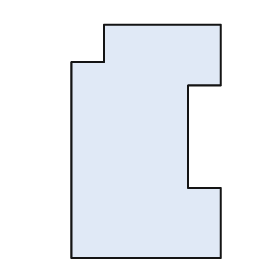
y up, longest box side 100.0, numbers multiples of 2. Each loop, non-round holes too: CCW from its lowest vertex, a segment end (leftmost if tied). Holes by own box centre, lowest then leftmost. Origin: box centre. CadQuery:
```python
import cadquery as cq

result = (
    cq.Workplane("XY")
    .moveTo(-32.0, -50.0)
    .lineTo(32.0, -50.0)
    .lineTo(32.0, -20.0)
    .lineTo(18.0, -20.0)
    .lineTo(18.0, 24.0)
    .lineTo(32.0, 24.0)
    .lineTo(32.0, 50.0)
    .lineTo(-18.0, 50.0)
    .lineTo(-18.0, 34.0)
    .lineTo(-32.0, 34.0)
    .close()
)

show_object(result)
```